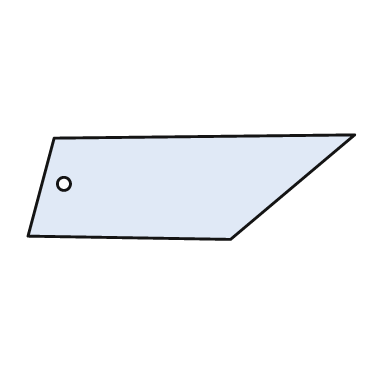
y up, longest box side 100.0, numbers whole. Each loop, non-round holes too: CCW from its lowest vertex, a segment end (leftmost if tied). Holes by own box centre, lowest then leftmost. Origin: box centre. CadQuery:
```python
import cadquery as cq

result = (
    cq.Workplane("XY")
    .moveTo(12.0, -16.0)
    .lineTo(50.0, 16.0)
    .lineTo(-42.0, 15.0)
    .lineTo(-50.0, -15.0)
    .close()
    .moveTo(-39.0, 1.0)
    .circle(2.0)
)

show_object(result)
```